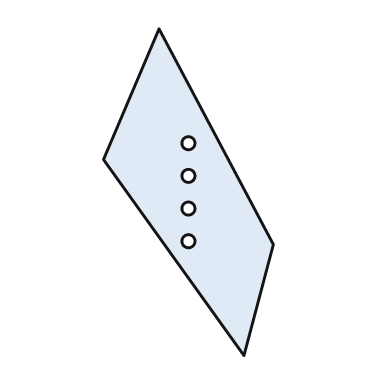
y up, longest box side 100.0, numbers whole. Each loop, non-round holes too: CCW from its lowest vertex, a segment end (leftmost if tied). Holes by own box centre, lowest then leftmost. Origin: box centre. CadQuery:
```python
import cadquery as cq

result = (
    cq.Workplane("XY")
    .moveTo(17.0, -50.0)
    .lineTo(26.0, -16.0)
    .lineTo(-9.0, 50.0)
    .lineTo(-26.0, 10.0)
    .close()
    .moveTo(0.0, -15.0)
    .circle(2.0)
    .moveTo(0.0, -5.0)
    .circle(2.0)
    .moveTo(0.0, 5.0)
    .circle(2.0)
    .moveTo(0.0, 15.0)
    .circle(2.0)
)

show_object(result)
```